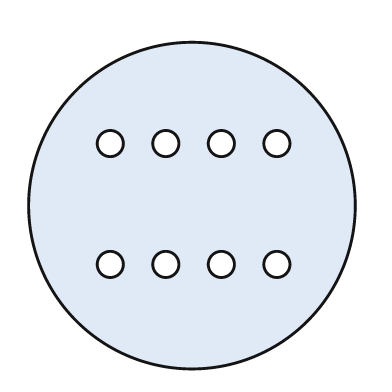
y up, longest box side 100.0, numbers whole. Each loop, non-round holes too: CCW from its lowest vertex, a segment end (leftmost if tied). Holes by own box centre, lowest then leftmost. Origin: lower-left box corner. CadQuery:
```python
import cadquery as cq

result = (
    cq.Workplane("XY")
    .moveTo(50.0, 50.0)
    .circle(50.0)
    .moveTo(25.0, 32.0)
    .circle(4.0)
    .moveTo(42.0, 32.0)
    .circle(4.0)
    .moveTo(59.0, 32.0)
    .circle(4.0)
    .moveTo(76.0, 32.0)
    .circle(4.0)
    .moveTo(25.0, 69.0)
    .circle(4.0)
    .moveTo(42.0, 69.0)
    .circle(4.0)
    .moveTo(59.0, 69.0)
    .circle(4.0)
    .moveTo(76.0, 69.0)
    .circle(4.0)
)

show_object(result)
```